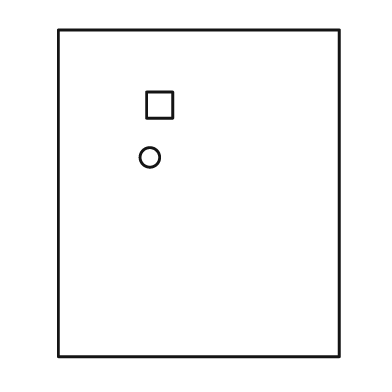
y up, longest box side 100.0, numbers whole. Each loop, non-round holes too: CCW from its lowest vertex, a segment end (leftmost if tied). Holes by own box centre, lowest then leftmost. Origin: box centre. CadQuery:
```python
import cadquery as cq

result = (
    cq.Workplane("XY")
    .moveTo(-43.0, -50.0)
    .lineTo(43.0, -50.0)
    .lineTo(43.0, 50.0)
    .lineTo(-43.0, 50.0)
    .close()
    .moveTo(-15.0, 11.0)
    .circle(3.0)
    .moveTo(-16.0, 23.0)
    .lineTo(-8.0, 23.0)
    .lineTo(-8.0, 31.0)
    .lineTo(-16.0, 31.0)
    .close()
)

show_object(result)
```